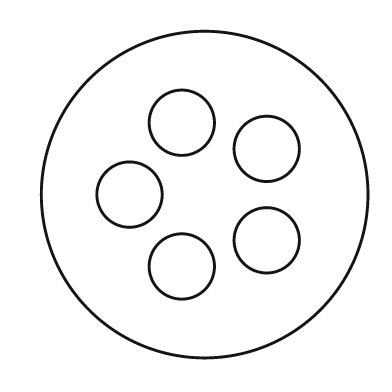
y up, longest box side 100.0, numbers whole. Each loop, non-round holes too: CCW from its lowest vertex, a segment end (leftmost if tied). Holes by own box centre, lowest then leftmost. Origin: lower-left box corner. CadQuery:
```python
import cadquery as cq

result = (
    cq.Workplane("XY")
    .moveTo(50.0, 50.0)
    .circle(50.0)
    .moveTo(43.0, 28.0)
    .circle(10.0)
    .moveTo(69.0, 36.0)
    .circle(10.0)
    .moveTo(27.0, 50.0)
    .circle(10.0)
    .moveTo(69.0, 64.0)
    .circle(10.0)
    .moveTo(43.0, 72.0)
    .circle(10.0)
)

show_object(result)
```